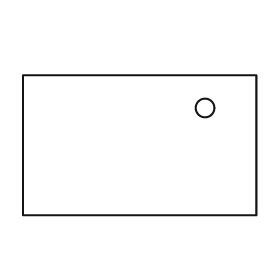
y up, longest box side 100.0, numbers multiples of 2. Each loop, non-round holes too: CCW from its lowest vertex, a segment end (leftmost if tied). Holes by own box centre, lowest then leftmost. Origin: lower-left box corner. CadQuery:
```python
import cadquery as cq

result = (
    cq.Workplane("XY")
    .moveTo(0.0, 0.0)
    .lineTo(100.0, 0.0)
    .lineTo(100.0, 60.0)
    .lineTo(0.0, 60.0)
    .close()
    .moveTo(78.0, 46.0)
    .circle(4.0)
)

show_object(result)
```